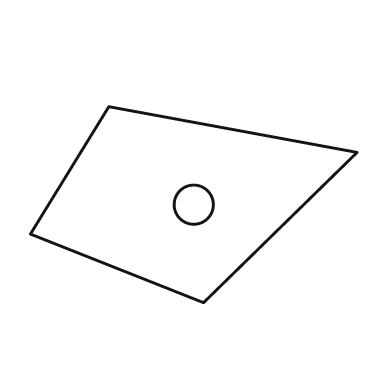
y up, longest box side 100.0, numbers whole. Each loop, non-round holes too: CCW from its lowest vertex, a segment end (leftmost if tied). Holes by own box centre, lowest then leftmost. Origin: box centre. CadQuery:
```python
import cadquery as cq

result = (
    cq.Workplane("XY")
    .moveTo(3.0, -30.0)
    .lineTo(50.0, 16.0)
    .lineTo(-26.0, 30.0)
    .lineTo(-50.0, -9.0)
    .close()
    .moveTo(0.0, 0.0)
    .circle(6.0)
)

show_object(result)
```